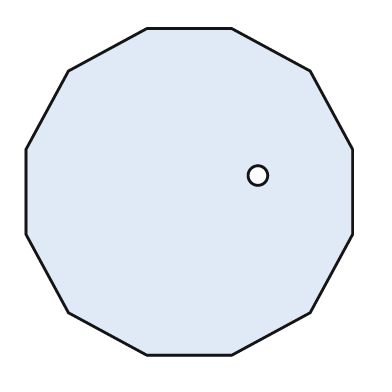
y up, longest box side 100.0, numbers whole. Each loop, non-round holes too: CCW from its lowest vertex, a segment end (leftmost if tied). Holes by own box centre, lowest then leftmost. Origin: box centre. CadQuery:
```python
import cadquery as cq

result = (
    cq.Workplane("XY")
    .moveTo(-13.0, -50.0)
    .lineTo(13.0, -50.0)
    .lineTo(37.0, -37.0)
    .lineTo(50.0, -13.0)
    .lineTo(50.0, 13.0)
    .lineTo(37.0, 37.0)
    .lineTo(13.0, 50.0)
    .lineTo(-13.0, 50.0)
    .lineTo(-37.0, 37.0)
    .lineTo(-50.0, 13.0)
    .lineTo(-50.0, -13.0)
    .lineTo(-37.0, -37.0)
    .close()
    .moveTo(21.0, 5.0)
    .circle(3.0)
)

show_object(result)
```